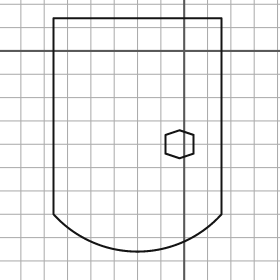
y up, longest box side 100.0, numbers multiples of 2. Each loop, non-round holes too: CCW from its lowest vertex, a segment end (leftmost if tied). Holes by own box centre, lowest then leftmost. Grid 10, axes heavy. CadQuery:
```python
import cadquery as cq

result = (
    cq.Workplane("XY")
    .moveTo(-56.0, -70.0)
    .threePointArc((-20.0, -86.0), (16.0, -70.0))
    .lineTo(16.0, 14.0)
    .lineTo(-56.0, 14.0)
    .close()
    .moveTo(-2.0, -46.0)
    .lineTo(4.0, -44.0)
    .lineTo(4.0, -36.0)
    .lineTo(-2.0, -34.0)
    .lineTo(-8.0, -36.0)
    .lineTo(-8.0, -44.0)
    .close()
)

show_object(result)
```